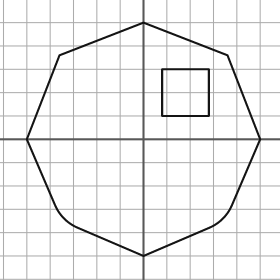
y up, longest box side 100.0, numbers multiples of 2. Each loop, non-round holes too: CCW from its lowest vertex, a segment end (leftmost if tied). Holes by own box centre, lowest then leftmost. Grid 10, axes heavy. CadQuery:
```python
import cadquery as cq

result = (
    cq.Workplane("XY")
    .moveTo(0.0, -50.0)
    .lineTo(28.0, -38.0)
    .threePointArc((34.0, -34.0), (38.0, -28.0))
    .lineTo(50.0, 0.0)
    .lineTo(36.0, 36.0)
    .lineTo(0.0, 50.0)
    .lineTo(-36.0, 36.0)
    .lineTo(-50.0, 0.0)
    .lineTo(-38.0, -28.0)
    .threePointArc((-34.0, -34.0), (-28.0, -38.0))
    .close()
    .moveTo(8.0, 10.0)
    .lineTo(28.0, 10.0)
    .lineTo(28.0, 30.0)
    .lineTo(8.0, 30.0)
    .close()
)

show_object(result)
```